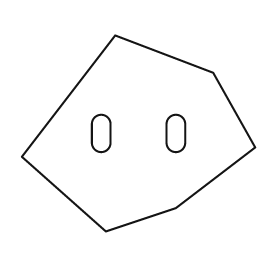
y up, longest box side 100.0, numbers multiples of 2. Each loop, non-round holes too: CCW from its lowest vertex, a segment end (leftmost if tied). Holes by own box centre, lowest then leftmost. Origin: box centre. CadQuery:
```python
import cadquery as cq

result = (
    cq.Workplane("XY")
    .moveTo(-14.0, -42.0)
    .lineTo(16.0, -32.0)
    .lineTo(50.0, -6.0)
    .lineTo(32.0, 26.0)
    .lineTo(-10.0, 42.0)
    .lineTo(-50.0, -10.0)
    .close()
    .moveTo(-20.0, -4.0)
    .threePointArc((-16.0, -8.0), (-12.0, -4.0))
    .lineTo(-12.0, 4.0)
    .threePointArc((-16.0, 8.0), (-20.0, 4.0))
    .close()
    .moveTo(12.0, -4.0)
    .threePointArc((16.0, -8.0), (20.0, -4.0))
    .lineTo(20.0, 4.0)
    .threePointArc((16.0, 8.0), (12.0, 4.0))
    .close()
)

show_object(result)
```